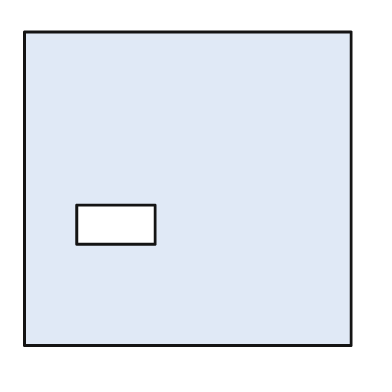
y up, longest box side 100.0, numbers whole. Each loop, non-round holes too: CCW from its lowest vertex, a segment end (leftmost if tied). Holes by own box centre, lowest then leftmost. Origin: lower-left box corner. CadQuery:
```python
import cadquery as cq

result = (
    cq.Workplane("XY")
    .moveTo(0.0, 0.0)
    .lineTo(100.0, 0.0)
    .lineTo(100.0, 96.0)
    .lineTo(0.0, 96.0)
    .close()
    .moveTo(16.0, 31.0)
    .lineTo(40.0, 31.0)
    .lineTo(40.0, 43.0)
    .lineTo(16.0, 43.0)
    .close()
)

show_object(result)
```